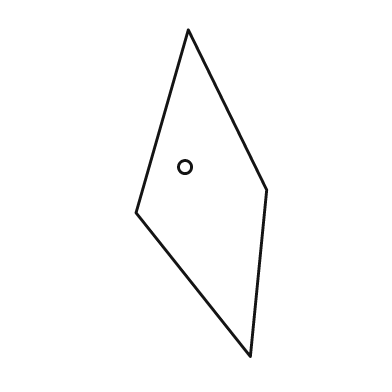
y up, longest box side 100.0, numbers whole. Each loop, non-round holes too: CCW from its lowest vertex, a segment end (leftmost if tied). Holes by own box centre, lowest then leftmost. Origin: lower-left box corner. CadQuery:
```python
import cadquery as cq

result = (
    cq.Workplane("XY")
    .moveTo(35.0, 0.0)
    .lineTo(40.0, 51.0)
    .lineTo(16.0, 100.0)
    .lineTo(0.0, 44.0)
    .close()
    .moveTo(15.0, 58.0)
    .circle(2.0)
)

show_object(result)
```